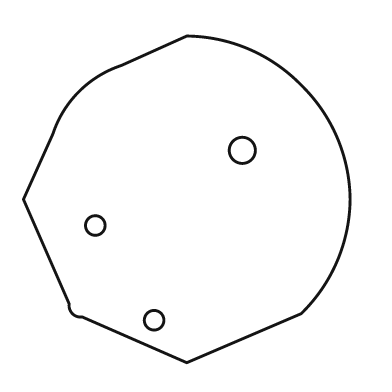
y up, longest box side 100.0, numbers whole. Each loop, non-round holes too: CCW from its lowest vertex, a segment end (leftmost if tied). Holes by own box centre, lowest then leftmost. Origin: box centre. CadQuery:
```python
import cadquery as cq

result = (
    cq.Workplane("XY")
    .moveTo(0.0, -50.0)
    .lineTo(35.0, -35.0)
    .threePointArc((46.0, -19.0), (50.0, 0.0))
    .threePointArc((46.0, 19.0), (35.0, 35.0))
    .threePointArc((19.0, 46.0), (0.0, 50.0))
    .lineTo(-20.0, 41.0)
    .threePointArc((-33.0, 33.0), (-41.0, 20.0))
    .lineTo(-50.0, 0.0)
    .lineTo(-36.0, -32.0)
    .threePointArc((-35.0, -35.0), (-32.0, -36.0))
    .close()
    .moveTo(-10.0, -37.0)
    .circle(3.0)
    .moveTo(-28.0, -8.0)
    .circle(3.0)
    .moveTo(17.0, 15.0)
    .circle(4.0)
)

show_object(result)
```